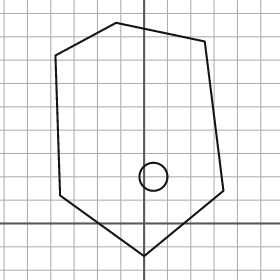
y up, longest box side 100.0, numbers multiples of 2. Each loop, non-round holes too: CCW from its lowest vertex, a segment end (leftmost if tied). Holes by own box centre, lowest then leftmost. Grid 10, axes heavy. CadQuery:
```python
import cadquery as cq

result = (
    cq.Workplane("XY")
    .moveTo(0.0, -14.0)
    .lineTo(34.0, 14.0)
    .lineTo(26.0, 78.0)
    .lineTo(-12.0, 86.0)
    .lineTo(-38.0, 72.0)
    .lineTo(-36.0, 12.0)
    .close()
    .moveTo(4.0, 20.0)
    .circle(6.0)
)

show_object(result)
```